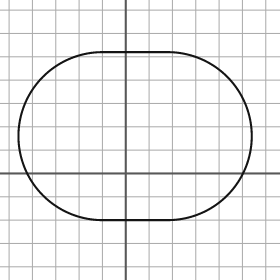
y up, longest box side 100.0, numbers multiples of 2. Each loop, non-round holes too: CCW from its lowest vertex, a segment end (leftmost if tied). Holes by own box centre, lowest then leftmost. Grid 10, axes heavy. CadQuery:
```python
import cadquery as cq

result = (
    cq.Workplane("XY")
    .moveTo(-10.0, -20.0)
    .lineTo(18.0, -20.0)
    .threePointArc((54.0, 16.0), (18.0, 52.0))
    .lineTo(-10.0, 52.0)
    .threePointArc((-46.0, 16.0), (-10.0, -20.0))
    .close()
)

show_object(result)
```